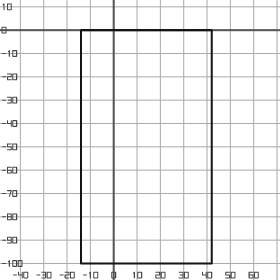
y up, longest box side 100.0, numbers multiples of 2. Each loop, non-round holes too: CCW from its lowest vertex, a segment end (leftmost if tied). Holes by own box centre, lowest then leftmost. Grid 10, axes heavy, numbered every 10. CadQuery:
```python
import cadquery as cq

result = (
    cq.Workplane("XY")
    .moveTo(-14.0, -100.0)
    .lineTo(42.0, -100.0)
    .lineTo(42.0, 0.0)
    .lineTo(-14.0, 0.0)
    .close()
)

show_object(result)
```